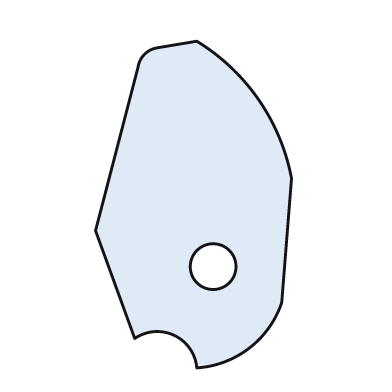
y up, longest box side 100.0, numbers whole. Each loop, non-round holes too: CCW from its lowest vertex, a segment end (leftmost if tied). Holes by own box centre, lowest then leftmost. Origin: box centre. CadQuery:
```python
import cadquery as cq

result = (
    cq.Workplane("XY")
    .moveTo(1.0, -50.0)
    .threePointArc((17.0, -44.0), (27.0, -30.0))
    .lineTo(30.0, 8.0)
    .threePointArc((20.0, 32.0), (1.0, 50.0))
    .lineTo(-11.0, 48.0)
    .threePointArc((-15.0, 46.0), (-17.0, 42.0))
    .lineTo(-30.0, -8.0)
    .lineTo(-18.0, -41.0)
    .threePointArc((-6.0, -40.0), (1.0, -50.0))
    .close()
    .moveTo(6.0, -19.0)
    .circle(7.0)
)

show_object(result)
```